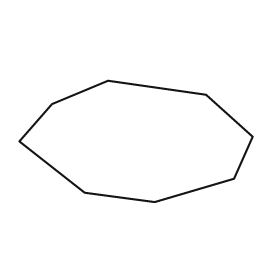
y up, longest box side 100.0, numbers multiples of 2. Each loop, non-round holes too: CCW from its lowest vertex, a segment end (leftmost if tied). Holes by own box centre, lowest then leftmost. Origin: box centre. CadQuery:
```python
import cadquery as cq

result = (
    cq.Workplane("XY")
    .moveTo(8.0, -26.0)
    .lineTo(42.0, -16.0)
    .lineTo(50.0, 2.0)
    .lineTo(30.0, 20.0)
    .lineTo(-12.0, 26.0)
    .lineTo(-36.0, 16.0)
    .lineTo(-50.0, 0.0)
    .lineTo(-22.0, -22.0)
    .close()
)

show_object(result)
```